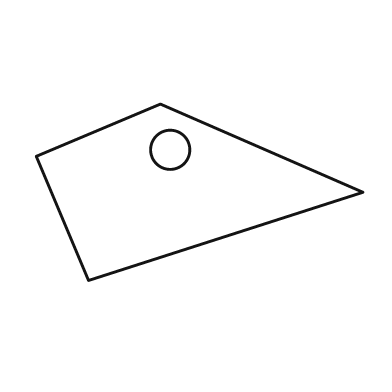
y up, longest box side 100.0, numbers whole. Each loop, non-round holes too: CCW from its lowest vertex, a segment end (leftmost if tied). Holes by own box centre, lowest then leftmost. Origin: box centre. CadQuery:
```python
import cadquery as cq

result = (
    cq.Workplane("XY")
    .moveTo(-34.0, -27.0)
    .lineTo(50.0, 0.0)
    .lineTo(-12.0, 27.0)
    .lineTo(-50.0, 11.0)
    .close()
    .moveTo(-9.0, 13.0)
    .circle(6.0)
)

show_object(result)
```